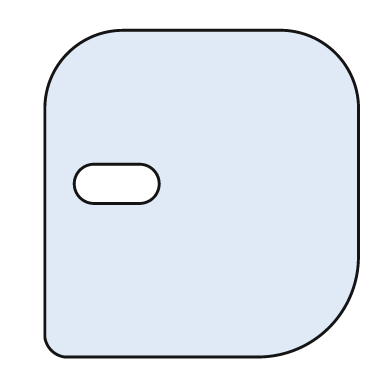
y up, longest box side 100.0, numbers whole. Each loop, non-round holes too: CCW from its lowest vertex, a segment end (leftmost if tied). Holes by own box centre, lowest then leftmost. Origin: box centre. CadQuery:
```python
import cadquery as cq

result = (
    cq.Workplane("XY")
    .moveTo(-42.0, -50.0)
    .lineTo(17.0, -50.0)
    .threePointArc((39.0, -41.0), (48.0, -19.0))
    .lineTo(48.0, 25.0)
    .threePointArc((41.0, 43.0), (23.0, 50.0))
    .lineTo(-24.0, 50.0)
    .threePointArc((-41.0, 43.0), (-48.0, 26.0))
    .lineTo(-48.0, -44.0)
    .threePointArc((-46.0, -48.0), (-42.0, -50.0))
    .close()
    .moveTo(-33.0, -3.0)
    .lineTo(-19.0, -3.0)
    .threePointArc((-13.0, 3.0), (-19.0, 9.0))
    .lineTo(-33.0, 9.0)
    .threePointArc((-39.0, 3.0), (-33.0, -3.0))
    .close()
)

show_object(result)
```